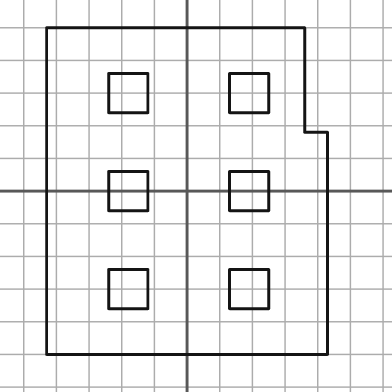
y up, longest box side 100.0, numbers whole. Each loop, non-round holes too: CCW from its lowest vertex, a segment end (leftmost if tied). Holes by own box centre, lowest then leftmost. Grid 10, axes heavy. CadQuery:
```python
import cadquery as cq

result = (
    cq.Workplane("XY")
    .moveTo(-43.0, -50.0)
    .lineTo(43.0, -50.0)
    .lineTo(43.0, 18.0)
    .lineTo(36.0, 18.0)
    .lineTo(36.0, 50.0)
    .lineTo(-43.0, 50.0)
    .close()
    .moveTo(-24.0, -36.0)
    .lineTo(-12.0, -36.0)
    .lineTo(-12.0, -24.0)
    .lineTo(-24.0, -24.0)
    .close()
    .moveTo(13.0, -36.0)
    .lineTo(25.0, -36.0)
    .lineTo(25.0, -24.0)
    .lineTo(13.0, -24.0)
    .close()
    .moveTo(-24.0, -6.0)
    .lineTo(-12.0, -6.0)
    .lineTo(-12.0, 6.0)
    .lineTo(-24.0, 6.0)
    .close()
    .moveTo(13.0, -6.0)
    .lineTo(25.0, -6.0)
    .lineTo(25.0, 6.0)
    .lineTo(13.0, 6.0)
    .close()
    .moveTo(-24.0, 24.0)
    .lineTo(-12.0, 24.0)
    .lineTo(-12.0, 36.0)
    .lineTo(-24.0, 36.0)
    .close()
    .moveTo(13.0, 24.0)
    .lineTo(25.0, 24.0)
    .lineTo(25.0, 36.0)
    .lineTo(13.0, 36.0)
    .close()
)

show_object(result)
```